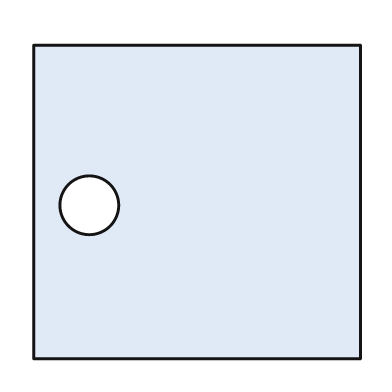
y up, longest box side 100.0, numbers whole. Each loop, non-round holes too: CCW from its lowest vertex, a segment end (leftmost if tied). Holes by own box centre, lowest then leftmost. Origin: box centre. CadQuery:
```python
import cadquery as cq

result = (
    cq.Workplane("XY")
    .moveTo(-50.0, -48.0)
    .lineTo(50.0, -48.0)
    .lineTo(50.0, 48.0)
    .lineTo(-50.0, 48.0)
    .close()
    .moveTo(-33.0, -1.0)
    .circle(9.0)
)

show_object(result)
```